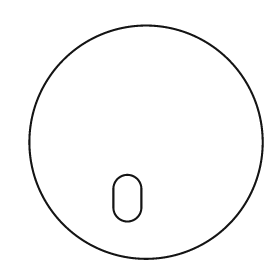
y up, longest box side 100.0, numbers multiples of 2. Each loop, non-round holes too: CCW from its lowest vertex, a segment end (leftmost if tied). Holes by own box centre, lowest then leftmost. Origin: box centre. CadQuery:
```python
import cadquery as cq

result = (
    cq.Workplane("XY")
    .moveTo(0.0, 0.0)
    .circle(50.0)
    .moveTo(-14.0, -28.0)
    .threePointArc((-8.0, -34.0), (-2.0, -28.0))
    .lineTo(-2.0, -20.0)
    .threePointArc((-8.0, -14.0), (-14.0, -20.0))
    .close()
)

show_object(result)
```